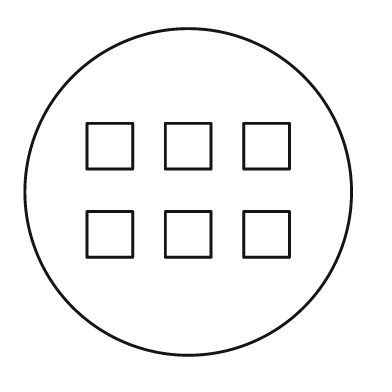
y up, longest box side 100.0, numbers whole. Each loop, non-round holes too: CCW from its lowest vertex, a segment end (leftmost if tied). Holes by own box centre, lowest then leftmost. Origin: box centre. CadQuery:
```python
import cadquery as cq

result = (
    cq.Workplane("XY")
    .moveTo(0.0, 0.0)
    .circle(50.0)
    .moveTo(-31.0, -20.0)
    .lineTo(-17.0, -20.0)
    .lineTo(-17.0, -6.0)
    .lineTo(-31.0, -6.0)
    .close()
    .moveTo(-7.0, -20.0)
    .lineTo(7.0, -20.0)
    .lineTo(7.0, -6.0)
    .lineTo(-7.0, -6.0)
    .close()
    .moveTo(17.0, -20.0)
    .lineTo(31.0, -20.0)
    .lineTo(31.0, -6.0)
    .lineTo(17.0, -6.0)
    .close()
    .moveTo(-31.0, 7.0)
    .lineTo(-17.0, 7.0)
    .lineTo(-17.0, 21.0)
    .lineTo(-31.0, 21.0)
    .close()
    .moveTo(-7.0, 7.0)
    .lineTo(7.0, 7.0)
    .lineTo(7.0, 21.0)
    .lineTo(-7.0, 21.0)
    .close()
    .moveTo(17.0, 7.0)
    .lineTo(31.0, 7.0)
    .lineTo(31.0, 21.0)
    .lineTo(17.0, 21.0)
    .close()
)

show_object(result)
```